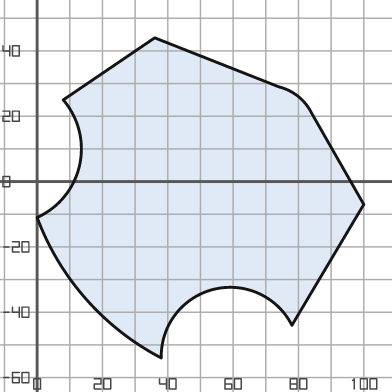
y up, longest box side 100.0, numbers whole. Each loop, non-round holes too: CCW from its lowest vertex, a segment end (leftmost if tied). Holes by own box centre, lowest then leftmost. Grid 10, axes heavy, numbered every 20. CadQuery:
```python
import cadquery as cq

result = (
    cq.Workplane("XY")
    .moveTo(38.0, -54.0)
    .threePointArc((54.0, -33.0), (78.0, -44.0))
    .lineTo(100.0, -7.0)
    .lineTo(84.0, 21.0)
    .threePointArc((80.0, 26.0), (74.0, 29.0))
    .lineTo(36.0, 44.0)
    .lineTo(8.0, 25.0)
    .threePointArc((13.0, 5.0), (0.0, -11.0))
    .threePointArc((15.0, -36.0), (38.0, -54.0))
    .close()
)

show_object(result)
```